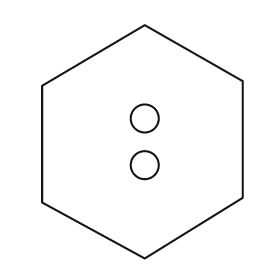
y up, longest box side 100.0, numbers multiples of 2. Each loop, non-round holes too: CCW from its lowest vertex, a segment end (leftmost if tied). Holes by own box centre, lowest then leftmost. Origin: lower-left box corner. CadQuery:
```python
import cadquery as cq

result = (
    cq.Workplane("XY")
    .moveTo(44.0, 0.0)
    .lineTo(86.0, 26.0)
    .lineTo(86.0, 76.0)
    .lineTo(44.0, 100.0)
    .lineTo(0.0, 74.0)
    .lineTo(0.0, 24.0)
    .close()
    .moveTo(44.0, 40.0)
    .circle(6.0)
    .moveTo(44.0, 60.0)
    .circle(6.0)
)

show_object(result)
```